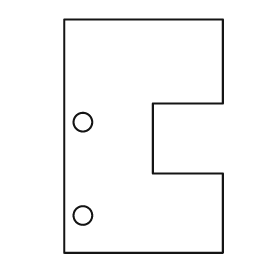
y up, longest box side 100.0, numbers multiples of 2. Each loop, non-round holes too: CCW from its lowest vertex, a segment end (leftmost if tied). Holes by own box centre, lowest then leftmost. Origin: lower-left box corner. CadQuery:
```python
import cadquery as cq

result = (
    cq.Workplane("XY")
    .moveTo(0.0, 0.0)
    .lineTo(68.0, 0.0)
    .lineTo(68.0, 34.0)
    .lineTo(38.0, 34.0)
    .lineTo(38.0, 64.0)
    .lineTo(68.0, 64.0)
    .lineTo(68.0, 100.0)
    .lineTo(0.0, 100.0)
    .close()
    .moveTo(8.0, 16.0)
    .circle(4.0)
    .moveTo(8.0, 56.0)
    .circle(4.0)
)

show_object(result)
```